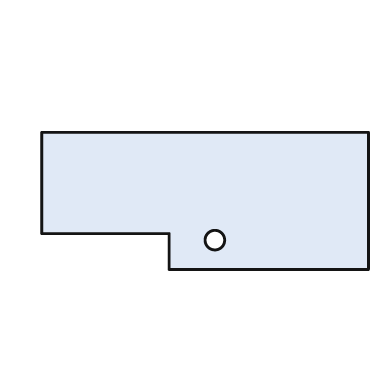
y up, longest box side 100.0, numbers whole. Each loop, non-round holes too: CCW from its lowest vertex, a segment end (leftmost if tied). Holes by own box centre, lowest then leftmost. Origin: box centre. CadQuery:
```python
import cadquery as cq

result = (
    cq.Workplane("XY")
    .moveTo(-11.0, -21.0)
    .lineTo(50.0, -21.0)
    .lineTo(50.0, 21.0)
    .lineTo(-50.0, 21.0)
    .lineTo(-50.0, -10.0)
    .lineTo(-11.0, -10.0)
    .close()
    .moveTo(3.0, -12.0)
    .circle(3.0)
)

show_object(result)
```